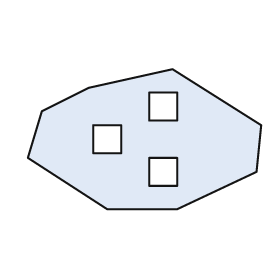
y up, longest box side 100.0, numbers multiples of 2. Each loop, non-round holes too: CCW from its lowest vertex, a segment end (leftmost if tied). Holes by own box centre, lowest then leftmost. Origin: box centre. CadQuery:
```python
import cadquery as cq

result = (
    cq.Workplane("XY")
    .moveTo(-16.0, -30.0)
    .lineTo(14.0, -30.0)
    .lineTo(48.0, -14.0)
    .lineTo(50.0, 6.0)
    .lineTo(12.0, 30.0)
    .lineTo(-24.0, 22.0)
    .lineTo(-44.0, 12.0)
    .lineTo(-50.0, -8.0)
    .close()
    .moveTo(2.0, -20.0)
    .lineTo(14.0, -20.0)
    .lineTo(14.0, -8.0)
    .lineTo(2.0, -8.0)
    .close()
    .moveTo(-22.0, -6.0)
    .lineTo(-10.0, -6.0)
    .lineTo(-10.0, 6.0)
    .lineTo(-22.0, 6.0)
    .close()
    .moveTo(2.0, 8.0)
    .lineTo(14.0, 8.0)
    .lineTo(14.0, 20.0)
    .lineTo(2.0, 20.0)
    .close()
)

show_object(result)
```